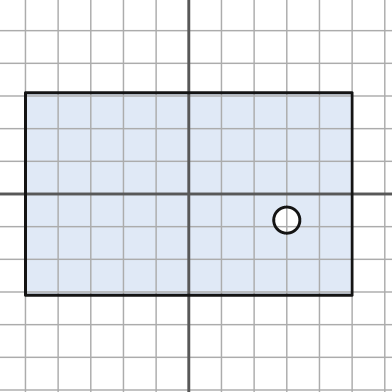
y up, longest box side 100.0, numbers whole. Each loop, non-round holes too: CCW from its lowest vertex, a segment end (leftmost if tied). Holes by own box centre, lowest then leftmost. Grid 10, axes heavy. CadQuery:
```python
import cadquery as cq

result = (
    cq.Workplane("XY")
    .moveTo(-50.0, -31.0)
    .lineTo(50.0, -31.0)
    .lineTo(50.0, 31.0)
    .lineTo(-50.0, 31.0)
    .close()
    .moveTo(30.0, -8.0)
    .circle(4.0)
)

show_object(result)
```